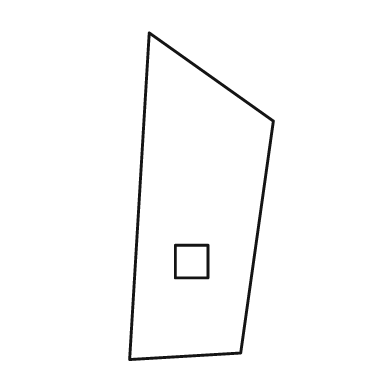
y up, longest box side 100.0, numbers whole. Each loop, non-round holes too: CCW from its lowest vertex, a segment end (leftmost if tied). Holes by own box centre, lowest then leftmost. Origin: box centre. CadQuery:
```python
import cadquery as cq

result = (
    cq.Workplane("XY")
    .moveTo(-22.0, -50.0)
    .lineTo(12.0, -48.0)
    .lineTo(22.0, 23.0)
    .lineTo(-16.0, 50.0)
    .close()
    .moveTo(-8.0, -25.0)
    .lineTo(2.0, -25.0)
    .lineTo(2.0, -15.0)
    .lineTo(-8.0, -15.0)
    .close()
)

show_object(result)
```